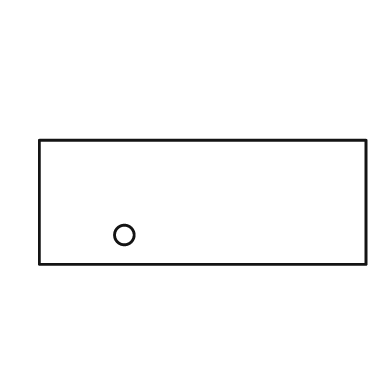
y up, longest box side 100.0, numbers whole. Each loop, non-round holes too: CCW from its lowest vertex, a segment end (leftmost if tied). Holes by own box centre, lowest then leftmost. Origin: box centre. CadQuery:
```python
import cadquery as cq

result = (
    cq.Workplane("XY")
    .moveTo(-50.0, -19.0)
    .lineTo(50.0, -19.0)
    .lineTo(50.0, 19.0)
    .lineTo(-50.0, 19.0)
    .close()
    .moveTo(-24.0, -10.0)
    .circle(3.0)
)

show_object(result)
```